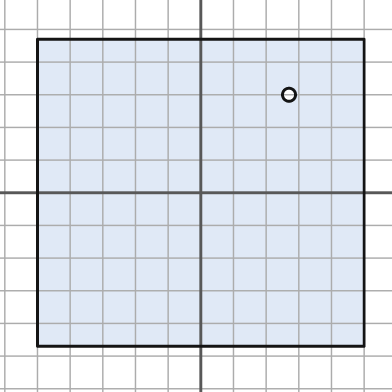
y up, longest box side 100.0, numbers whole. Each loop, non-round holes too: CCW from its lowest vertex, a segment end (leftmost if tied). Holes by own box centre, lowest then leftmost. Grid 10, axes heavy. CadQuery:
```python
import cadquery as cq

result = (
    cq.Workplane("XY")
    .moveTo(-50.0, -47.0)
    .lineTo(50.0, -47.0)
    .lineTo(50.0, 47.0)
    .lineTo(-50.0, 47.0)
    .close()
    .moveTo(27.0, 30.0)
    .circle(2.0)
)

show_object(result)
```